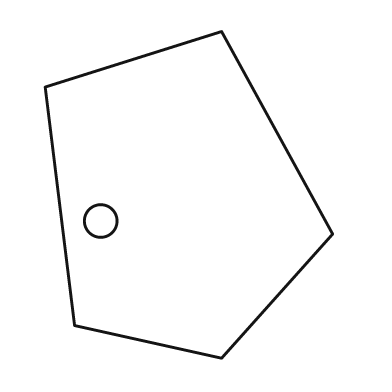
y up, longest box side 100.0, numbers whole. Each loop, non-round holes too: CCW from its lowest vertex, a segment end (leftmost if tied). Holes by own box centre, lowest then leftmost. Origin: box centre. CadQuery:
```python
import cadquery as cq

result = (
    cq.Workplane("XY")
    .moveTo(10.0, -50.0)
    .lineTo(44.0, -12.0)
    .lineTo(10.0, 50.0)
    .lineTo(-44.0, 33.0)
    .lineTo(-35.0, -40.0)
    .close()
    .moveTo(-27.0, -8.0)
    .circle(5.0)
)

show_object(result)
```